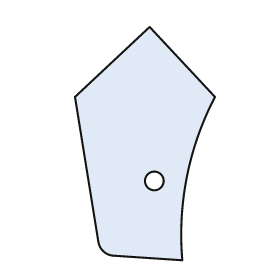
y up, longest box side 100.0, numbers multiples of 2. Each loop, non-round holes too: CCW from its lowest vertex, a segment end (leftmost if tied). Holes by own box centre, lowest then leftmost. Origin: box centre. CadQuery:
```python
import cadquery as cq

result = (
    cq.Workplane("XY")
    .moveTo(16.0, -50.0)
    .threePointArc((18.0, -14.0), (30.0, 20.0))
    .lineTo(2.0, 50.0)
    .lineTo(-30.0, 20.0)
    .lineTo(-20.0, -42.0)
    .threePointArc((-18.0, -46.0), (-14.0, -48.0))
    .close()
    .moveTo(4.0, -16.0)
    .circle(4.0)
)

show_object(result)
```